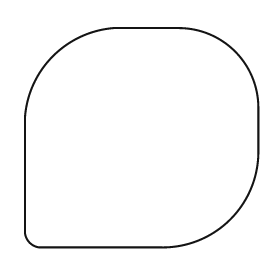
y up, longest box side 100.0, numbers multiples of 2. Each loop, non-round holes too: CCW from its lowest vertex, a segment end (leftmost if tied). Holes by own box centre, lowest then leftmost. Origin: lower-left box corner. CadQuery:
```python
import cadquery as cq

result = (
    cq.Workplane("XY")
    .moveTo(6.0, 0.0)
    .lineTo(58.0, 0.0)
    .threePointArc((88.0, 12.0), (100.0, 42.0))
    .lineTo(100.0, 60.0)
    .threePointArc((90.0, 84.0), (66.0, 94.0))
    .lineTo(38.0, 94.0)
    .threePointArc((12.0, 82.0), (0.0, 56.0))
    .lineTo(0.0, 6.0)
    .threePointArc((2.0, 2.0), (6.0, 0.0))
    .close()
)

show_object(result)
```